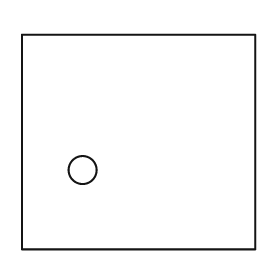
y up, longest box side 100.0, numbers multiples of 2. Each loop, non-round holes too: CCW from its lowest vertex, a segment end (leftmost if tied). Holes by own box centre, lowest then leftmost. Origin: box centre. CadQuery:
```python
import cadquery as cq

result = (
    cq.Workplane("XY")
    .moveTo(-50.0, -46.0)
    .lineTo(50.0, -46.0)
    .lineTo(50.0, 46.0)
    .lineTo(-50.0, 46.0)
    .close()
    .moveTo(-24.0, -12.0)
    .circle(6.0)
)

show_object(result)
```